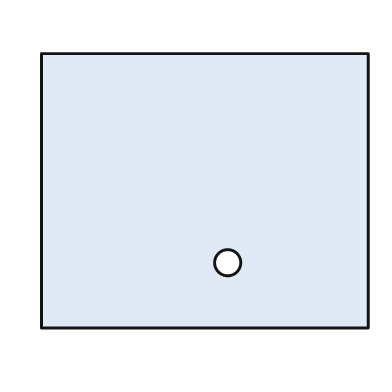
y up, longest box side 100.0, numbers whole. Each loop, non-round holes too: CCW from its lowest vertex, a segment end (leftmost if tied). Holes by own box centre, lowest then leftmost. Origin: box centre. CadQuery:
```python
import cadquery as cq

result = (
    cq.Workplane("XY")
    .moveTo(-50.0, -42.0)
    .lineTo(50.0, -42.0)
    .lineTo(50.0, 42.0)
    .lineTo(-50.0, 42.0)
    .close()
    .moveTo(7.0, -22.0)
    .circle(4.0)
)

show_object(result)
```